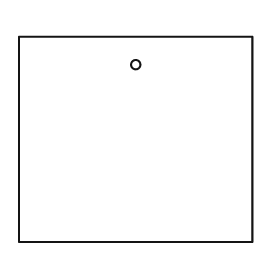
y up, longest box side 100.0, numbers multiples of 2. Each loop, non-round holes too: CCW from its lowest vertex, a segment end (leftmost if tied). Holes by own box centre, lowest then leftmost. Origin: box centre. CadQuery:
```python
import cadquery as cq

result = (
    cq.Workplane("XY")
    .moveTo(-50.0, -44.0)
    .lineTo(50.0, -44.0)
    .lineTo(50.0, 44.0)
    .lineTo(-50.0, 44.0)
    .close()
    .moveTo(0.0, 32.0)
    .circle(2.0)
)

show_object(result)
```